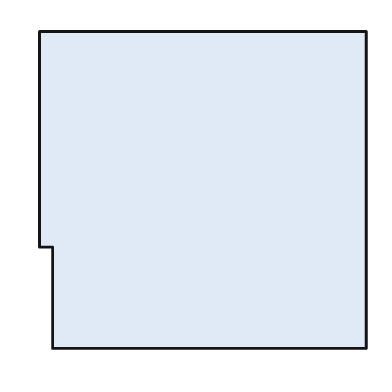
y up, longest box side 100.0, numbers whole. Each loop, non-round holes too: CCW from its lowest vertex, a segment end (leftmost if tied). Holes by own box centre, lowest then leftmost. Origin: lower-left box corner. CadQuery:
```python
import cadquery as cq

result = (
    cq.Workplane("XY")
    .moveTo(4.0, 0.0)
    .lineTo(100.0, 0.0)
    .lineTo(100.0, 97.0)
    .lineTo(0.0, 97.0)
    .lineTo(0.0, 31.0)
    .lineTo(4.0, 31.0)
    .close()
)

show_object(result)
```